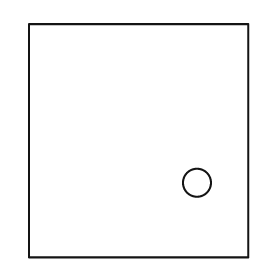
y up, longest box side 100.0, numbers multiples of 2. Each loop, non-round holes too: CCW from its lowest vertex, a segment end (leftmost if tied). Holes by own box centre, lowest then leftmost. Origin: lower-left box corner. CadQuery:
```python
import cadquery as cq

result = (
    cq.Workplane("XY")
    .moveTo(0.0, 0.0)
    .lineTo(94.0, 0.0)
    .lineTo(94.0, 100.0)
    .lineTo(0.0, 100.0)
    .close()
    .moveTo(72.0, 32.0)
    .circle(6.0)
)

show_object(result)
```